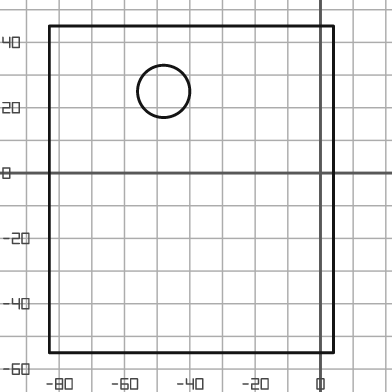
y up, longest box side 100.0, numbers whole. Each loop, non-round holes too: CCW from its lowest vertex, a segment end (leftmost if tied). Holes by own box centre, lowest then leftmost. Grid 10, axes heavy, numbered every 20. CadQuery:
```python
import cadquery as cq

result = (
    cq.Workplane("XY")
    .moveTo(-83.0, -55.0)
    .lineTo(4.0, -55.0)
    .lineTo(4.0, 45.0)
    .lineTo(-83.0, 45.0)
    .close()
    .moveTo(-48.0, 25.0)
    .circle(8.0)
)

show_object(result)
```